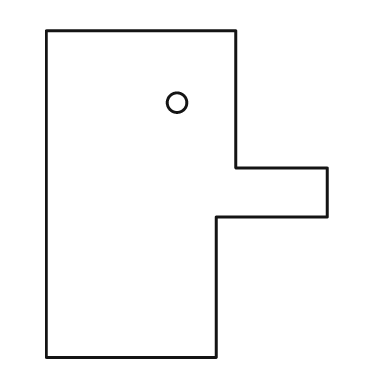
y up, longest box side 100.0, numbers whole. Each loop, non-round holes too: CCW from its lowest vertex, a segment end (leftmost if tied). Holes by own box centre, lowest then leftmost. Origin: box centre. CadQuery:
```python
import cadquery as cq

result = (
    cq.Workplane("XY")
    .moveTo(-43.0, -50.0)
    .lineTo(9.0, -50.0)
    .lineTo(9.0, -7.0)
    .lineTo(43.0, -7.0)
    .lineTo(43.0, 8.0)
    .lineTo(15.0, 8.0)
    .lineTo(15.0, 50.0)
    .lineTo(-43.0, 50.0)
    .close()
    .moveTo(-3.0, 28.0)
    .circle(3.0)
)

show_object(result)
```